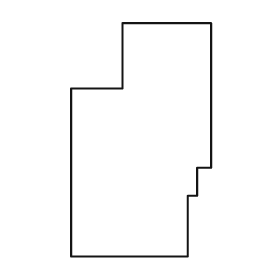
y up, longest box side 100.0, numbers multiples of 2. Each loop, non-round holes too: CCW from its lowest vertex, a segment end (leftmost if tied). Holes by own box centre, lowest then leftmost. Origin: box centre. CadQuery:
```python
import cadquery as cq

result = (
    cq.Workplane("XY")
    .moveTo(-30.0, -50.0)
    .lineTo(20.0, -50.0)
    .lineTo(20.0, -24.0)
    .lineTo(24.0, -24.0)
    .lineTo(24.0, -12.0)
    .lineTo(30.0, -12.0)
    .lineTo(30.0, 50.0)
    .lineTo(-8.0, 50.0)
    .lineTo(-8.0, 22.0)
    .lineTo(-30.0, 22.0)
    .close()
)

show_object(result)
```